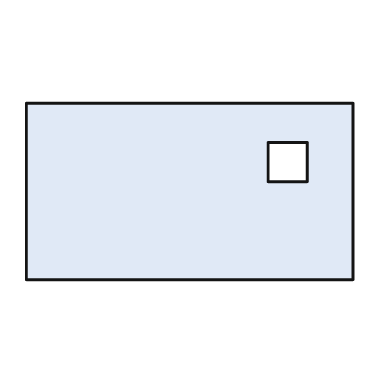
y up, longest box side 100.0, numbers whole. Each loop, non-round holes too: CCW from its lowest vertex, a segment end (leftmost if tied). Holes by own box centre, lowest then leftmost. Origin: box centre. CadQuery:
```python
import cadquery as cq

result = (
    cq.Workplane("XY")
    .moveTo(-50.0, -27.0)
    .lineTo(50.0, -27.0)
    .lineTo(50.0, 27.0)
    .lineTo(-50.0, 27.0)
    .close()
    .moveTo(24.0, 3.0)
    .lineTo(36.0, 3.0)
    .lineTo(36.0, 15.0)
    .lineTo(24.0, 15.0)
    .close()
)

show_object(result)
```